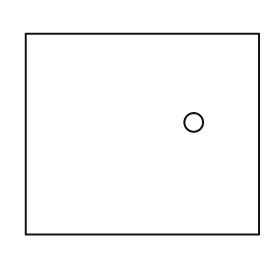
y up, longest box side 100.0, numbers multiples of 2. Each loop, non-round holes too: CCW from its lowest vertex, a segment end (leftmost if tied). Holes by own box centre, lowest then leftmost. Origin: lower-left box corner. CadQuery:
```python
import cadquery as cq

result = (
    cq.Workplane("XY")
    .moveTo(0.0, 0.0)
    .lineTo(100.0, 0.0)
    .lineTo(100.0, 86.0)
    .lineTo(0.0, 86.0)
    .close()
    .moveTo(72.0, 48.0)
    .circle(4.0)
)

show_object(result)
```